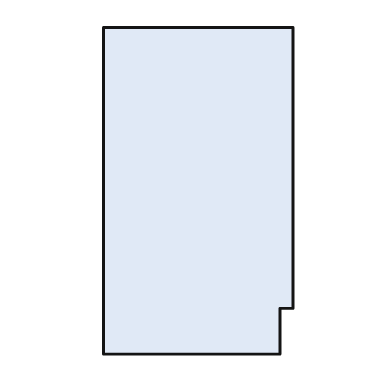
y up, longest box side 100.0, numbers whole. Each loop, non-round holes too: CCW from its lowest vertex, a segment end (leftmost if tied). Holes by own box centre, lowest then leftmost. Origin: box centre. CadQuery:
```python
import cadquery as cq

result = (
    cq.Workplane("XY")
    .moveTo(-29.0, -50.0)
    .lineTo(25.0, -50.0)
    .lineTo(25.0, -36.0)
    .lineTo(29.0, -36.0)
    .lineTo(29.0, 50.0)
    .lineTo(-29.0, 50.0)
    .close()
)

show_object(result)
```